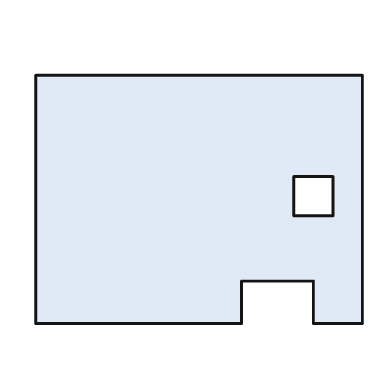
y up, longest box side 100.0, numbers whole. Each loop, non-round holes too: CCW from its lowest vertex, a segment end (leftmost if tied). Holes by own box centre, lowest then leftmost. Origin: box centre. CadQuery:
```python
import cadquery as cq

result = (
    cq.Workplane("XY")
    .moveTo(-50.0, -38.0)
    .lineTo(13.0, -38.0)
    .lineTo(13.0, -25.0)
    .lineTo(35.0, -25.0)
    .lineTo(35.0, -38.0)
    .lineTo(50.0, -38.0)
    .lineTo(50.0, 38.0)
    .lineTo(-50.0, 38.0)
    .close()
    .moveTo(29.0, -5.0)
    .lineTo(41.0, -5.0)
    .lineTo(41.0, 7.0)
    .lineTo(29.0, 7.0)
    .close()
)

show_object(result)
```